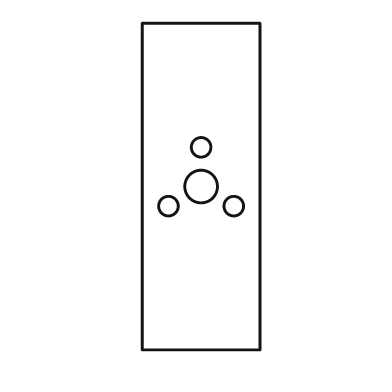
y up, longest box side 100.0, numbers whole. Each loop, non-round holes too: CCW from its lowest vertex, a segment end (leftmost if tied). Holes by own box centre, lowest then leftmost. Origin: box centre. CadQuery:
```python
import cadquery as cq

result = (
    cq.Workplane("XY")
    .moveTo(-18.0, -50.0)
    .lineTo(18.0, -50.0)
    .lineTo(18.0, 50.0)
    .lineTo(-18.0, 50.0)
    .close()
    .moveTo(-10.0, -6.0)
    .circle(3.0)
    .moveTo(10.0, -6.0)
    .circle(3.0)
    .moveTo(0.0, 0.0)
    .circle(5.0)
    .moveTo(0.0, 12.0)
    .circle(3.0)
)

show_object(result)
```